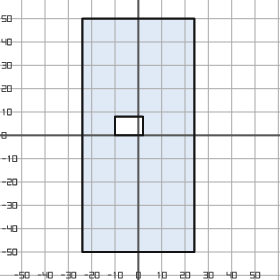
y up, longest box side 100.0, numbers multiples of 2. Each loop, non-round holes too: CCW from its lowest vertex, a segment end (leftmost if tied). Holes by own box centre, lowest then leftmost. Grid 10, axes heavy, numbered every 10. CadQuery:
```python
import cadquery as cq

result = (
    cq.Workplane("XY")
    .moveTo(-24.0, -50.0)
    .lineTo(24.0, -50.0)
    .lineTo(24.0, 50.0)
    .lineTo(-24.0, 50.0)
    .close()
    .moveTo(-10.0, 0.0)
    .lineTo(2.0, 0.0)
    .lineTo(2.0, 8.0)
    .lineTo(-10.0, 8.0)
    .close()
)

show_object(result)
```